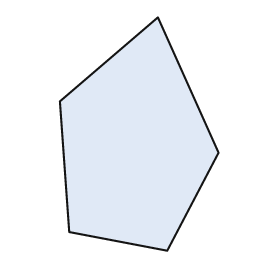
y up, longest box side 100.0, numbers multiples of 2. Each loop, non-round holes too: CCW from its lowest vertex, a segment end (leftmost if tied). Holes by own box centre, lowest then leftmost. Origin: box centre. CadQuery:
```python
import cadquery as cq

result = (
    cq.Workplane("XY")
    .moveTo(12.0, -50.0)
    .lineTo(34.0, -8.0)
    .lineTo(8.0, 50.0)
    .lineTo(-34.0, 14.0)
    .lineTo(-30.0, -42.0)
    .close()
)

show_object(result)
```